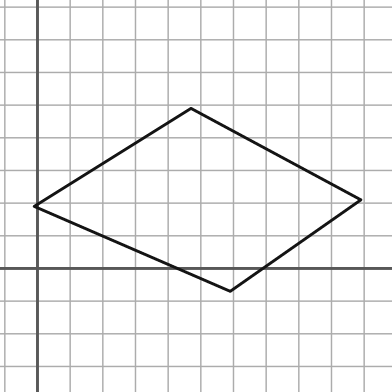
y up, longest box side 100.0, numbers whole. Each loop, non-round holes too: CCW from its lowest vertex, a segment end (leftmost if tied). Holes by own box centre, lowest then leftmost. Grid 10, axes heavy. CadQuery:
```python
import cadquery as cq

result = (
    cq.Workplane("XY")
    .moveTo(59.0, -7.0)
    .lineTo(99.0, 21.0)
    .lineTo(47.0, 49.0)
    .lineTo(-1.0, 19.0)
    .close()
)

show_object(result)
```